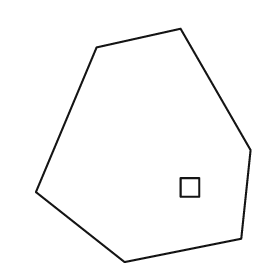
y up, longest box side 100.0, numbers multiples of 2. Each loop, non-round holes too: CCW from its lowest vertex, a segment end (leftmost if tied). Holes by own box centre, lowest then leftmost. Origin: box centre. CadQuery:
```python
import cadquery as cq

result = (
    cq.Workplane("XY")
    .moveTo(-8.0, -50.0)
    .lineTo(42.0, -40.0)
    .lineTo(46.0, -2.0)
    .lineTo(16.0, 50.0)
    .lineTo(-20.0, 42.0)
    .lineTo(-46.0, -20.0)
    .close()
    .moveTo(16.0, -22.0)
    .lineTo(24.0, -22.0)
    .lineTo(24.0, -14.0)
    .lineTo(16.0, -14.0)
    .close()
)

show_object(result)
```